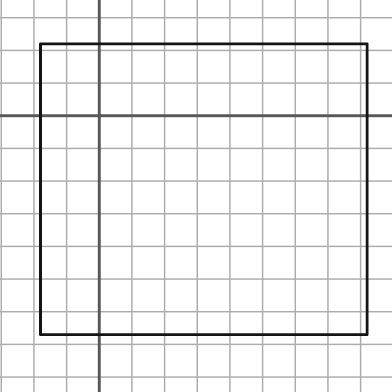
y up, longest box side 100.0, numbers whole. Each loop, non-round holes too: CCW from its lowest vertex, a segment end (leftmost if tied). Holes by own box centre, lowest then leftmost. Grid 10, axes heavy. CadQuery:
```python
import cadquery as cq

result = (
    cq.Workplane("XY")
    .moveTo(-18.0, -67.0)
    .lineTo(82.0, -67.0)
    .lineTo(82.0, 22.0)
    .lineTo(-18.0, 22.0)
    .close()
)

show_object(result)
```